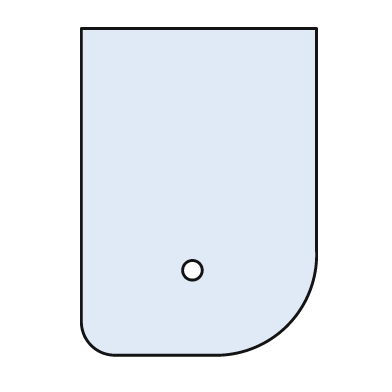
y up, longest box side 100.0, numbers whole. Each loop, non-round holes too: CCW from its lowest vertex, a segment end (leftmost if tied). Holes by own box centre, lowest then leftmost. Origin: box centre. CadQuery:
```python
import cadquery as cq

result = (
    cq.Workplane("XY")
    .moveTo(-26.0, -50.0)
    .lineTo(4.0, -50.0)
    .threePointArc((27.0, -41.0), (36.0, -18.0))
    .lineTo(36.0, 50.0)
    .lineTo(-36.0, 50.0)
    .lineTo(-36.0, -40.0)
    .threePointArc((-33.0, -47.0), (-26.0, -50.0))
    .close()
    .moveTo(-2.0, -24.0)
    .circle(3.0)
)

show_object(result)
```